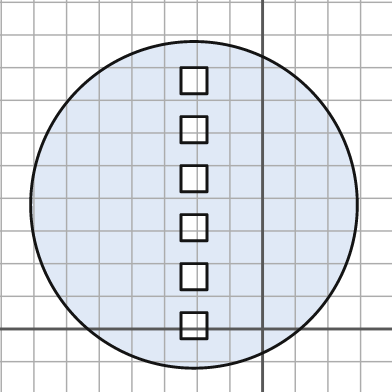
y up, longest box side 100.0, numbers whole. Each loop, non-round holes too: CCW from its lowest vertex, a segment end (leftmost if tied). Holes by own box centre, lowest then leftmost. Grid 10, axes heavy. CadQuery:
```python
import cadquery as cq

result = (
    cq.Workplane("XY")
    .moveTo(-21.0, 38.0)
    .circle(50.0)
    .moveTo(-25.0, -3.0)
    .lineTo(-17.0, -3.0)
    .lineTo(-17.0, 5.0)
    .lineTo(-25.0, 5.0)
    .close()
    .moveTo(-25.0, 12.0)
    .lineTo(-17.0, 12.0)
    .lineTo(-17.0, 20.0)
    .lineTo(-25.0, 20.0)
    .close()
    .moveTo(-25.0, 27.0)
    .lineTo(-17.0, 27.0)
    .lineTo(-17.0, 35.0)
    .lineTo(-25.0, 35.0)
    .close()
    .moveTo(-25.0, 42.0)
    .lineTo(-17.0, 42.0)
    .lineTo(-17.0, 50.0)
    .lineTo(-25.0, 50.0)
    .close()
    .moveTo(-25.0, 57.0)
    .lineTo(-17.0, 57.0)
    .lineTo(-17.0, 65.0)
    .lineTo(-25.0, 65.0)
    .close()
    .moveTo(-25.0, 72.0)
    .lineTo(-17.0, 72.0)
    .lineTo(-17.0, 80.0)
    .lineTo(-25.0, 80.0)
    .close()
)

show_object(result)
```